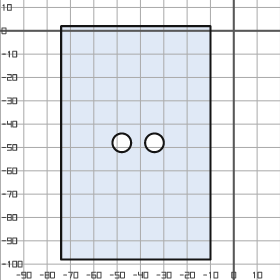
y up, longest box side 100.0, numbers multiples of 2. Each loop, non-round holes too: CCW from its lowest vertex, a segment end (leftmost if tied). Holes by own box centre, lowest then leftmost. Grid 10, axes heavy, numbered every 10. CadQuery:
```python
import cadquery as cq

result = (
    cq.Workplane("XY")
    .moveTo(-74.0, -98.0)
    .lineTo(-10.0, -98.0)
    .lineTo(-10.0, 2.0)
    .lineTo(-74.0, 2.0)
    .close()
    .moveTo(-48.0, -48.0)
    .circle(4.0)
    .moveTo(-34.0, -48.0)
    .circle(4.0)
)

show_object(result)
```